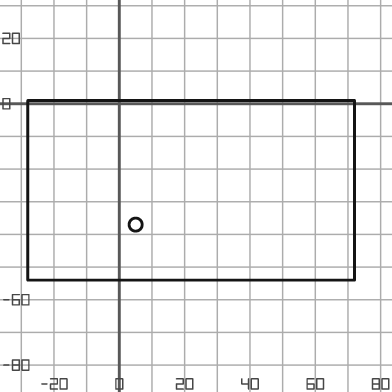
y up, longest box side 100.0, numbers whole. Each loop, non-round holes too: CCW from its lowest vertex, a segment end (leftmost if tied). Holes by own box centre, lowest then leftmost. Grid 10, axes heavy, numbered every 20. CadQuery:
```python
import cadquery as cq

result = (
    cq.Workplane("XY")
    .moveTo(-28.0, -54.0)
    .lineTo(72.0, -54.0)
    .lineTo(72.0, 1.0)
    .lineTo(-28.0, 1.0)
    .close()
    .moveTo(5.0, -37.0)
    .circle(2.0)
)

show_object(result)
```